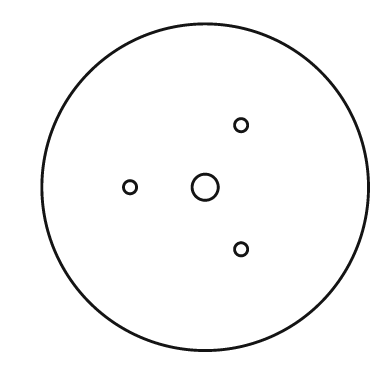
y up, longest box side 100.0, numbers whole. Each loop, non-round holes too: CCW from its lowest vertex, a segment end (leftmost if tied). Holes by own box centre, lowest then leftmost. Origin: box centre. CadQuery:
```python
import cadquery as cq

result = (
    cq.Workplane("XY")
    .moveTo(0.0, 0.0)
    .circle(50.0)
    .moveTo(11.0, -19.0)
    .circle(2.0)
    .moveTo(-23.0, 0.0)
    .circle(2.0)
    .moveTo(0.0, 0.0)
    .circle(4.0)
    .moveTo(11.0, 19.0)
    .circle(2.0)
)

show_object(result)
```